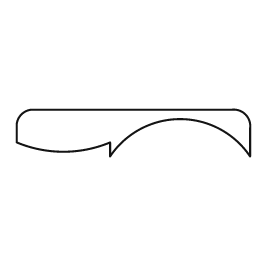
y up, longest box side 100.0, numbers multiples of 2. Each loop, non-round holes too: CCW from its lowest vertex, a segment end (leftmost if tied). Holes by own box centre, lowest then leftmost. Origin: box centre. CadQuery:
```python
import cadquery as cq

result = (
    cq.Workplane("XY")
    .moveTo(-10.0, -10.0)
    .threePointArc((20.0, 6.0), (50.0, -10.0))
    .lineTo(50.0, 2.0)
    .threePointArc((48.0, 8.0), (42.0, 10.0))
    .lineTo(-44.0, 10.0)
    .threePointArc((-48.0, 8.0), (-50.0, 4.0))
    .lineTo(-50.0, -4.0)
    .threePointArc((-30.0, -8.0), (-10.0, -4.0))
    .close()
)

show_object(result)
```